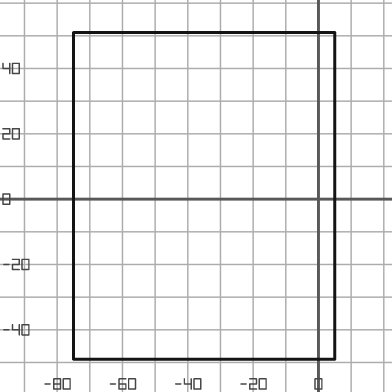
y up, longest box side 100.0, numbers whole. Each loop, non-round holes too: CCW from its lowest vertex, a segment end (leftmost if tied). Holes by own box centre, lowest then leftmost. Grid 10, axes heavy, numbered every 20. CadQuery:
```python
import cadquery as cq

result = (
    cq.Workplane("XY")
    .moveTo(-75.0, -49.0)
    .lineTo(5.0, -49.0)
    .lineTo(5.0, 51.0)
    .lineTo(-75.0, 51.0)
    .close()
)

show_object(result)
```